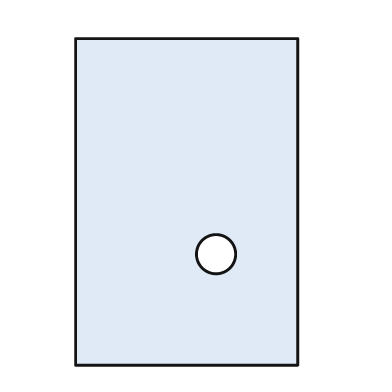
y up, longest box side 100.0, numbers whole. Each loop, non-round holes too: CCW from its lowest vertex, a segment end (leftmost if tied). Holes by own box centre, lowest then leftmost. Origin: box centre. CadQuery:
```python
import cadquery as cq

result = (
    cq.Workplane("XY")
    .moveTo(-34.0, -50.0)
    .lineTo(34.0, -50.0)
    .lineTo(34.0, 50.0)
    .lineTo(-34.0, 50.0)
    .close()
    .moveTo(9.0, -16.0)
    .circle(6.0)
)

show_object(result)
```